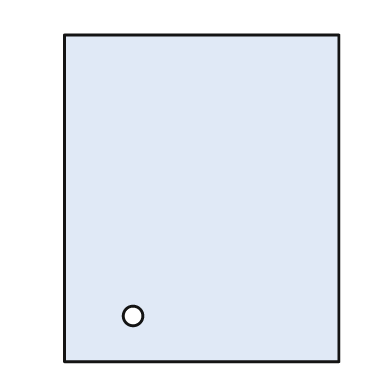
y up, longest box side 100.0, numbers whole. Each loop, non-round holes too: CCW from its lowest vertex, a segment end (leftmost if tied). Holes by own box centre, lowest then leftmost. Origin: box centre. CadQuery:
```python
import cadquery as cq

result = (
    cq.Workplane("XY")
    .moveTo(-42.0, -50.0)
    .lineTo(42.0, -50.0)
    .lineTo(42.0, 50.0)
    .lineTo(-42.0, 50.0)
    .close()
    .moveTo(-21.0, -36.0)
    .circle(3.0)
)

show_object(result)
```